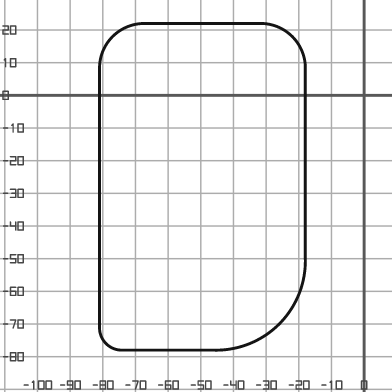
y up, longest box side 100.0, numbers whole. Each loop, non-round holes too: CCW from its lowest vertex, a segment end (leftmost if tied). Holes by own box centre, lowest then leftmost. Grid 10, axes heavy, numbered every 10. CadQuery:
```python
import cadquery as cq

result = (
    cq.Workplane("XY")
    .moveTo(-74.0, -78.0)
    .lineTo(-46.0, -78.0)
    .threePointArc((-26.0, -70.0), (-18.0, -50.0))
    .lineTo(-18.0, 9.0)
    .threePointArc((-22.0, 18.0), (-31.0, 22.0))
    .lineTo(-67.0, 22.0)
    .threePointArc((-77.0, 18.0), (-81.0, 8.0))
    .lineTo(-81.0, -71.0)
    .threePointArc((-79.0, -76.0), (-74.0, -78.0))
    .close()
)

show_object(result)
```